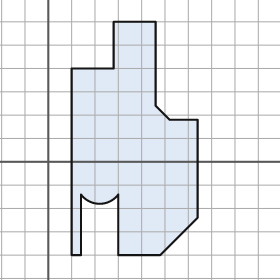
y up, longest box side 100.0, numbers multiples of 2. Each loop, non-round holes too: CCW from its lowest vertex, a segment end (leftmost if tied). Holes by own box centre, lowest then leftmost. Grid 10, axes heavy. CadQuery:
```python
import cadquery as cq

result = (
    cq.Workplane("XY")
    .moveTo(10.0, -40.0)
    .lineTo(14.0, -40.0)
    .lineTo(14.0, -14.0)
    .threePointArc((22.0, -18.0), (30.0, -14.0))
    .lineTo(30.0, -40.0)
    .lineTo(48.0, -40.0)
    .lineTo(64.0, -24.0)
    .lineTo(64.0, 18.0)
    .lineTo(52.0, 18.0)
    .lineTo(46.0, 24.0)
    .lineTo(46.0, 60.0)
    .lineTo(28.0, 60.0)
    .lineTo(28.0, 40.0)
    .lineTo(10.0, 40.0)
    .close()
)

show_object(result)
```